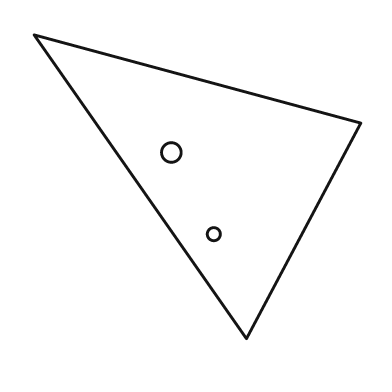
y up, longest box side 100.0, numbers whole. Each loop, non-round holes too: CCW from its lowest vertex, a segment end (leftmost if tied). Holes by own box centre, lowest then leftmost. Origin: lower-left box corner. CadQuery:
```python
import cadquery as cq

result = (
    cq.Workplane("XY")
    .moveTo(65.0, 0.0)
    .lineTo(100.0, 66.0)
    .lineTo(0.0, 93.0)
    .close()
    .moveTo(55.0, 32.0)
    .circle(2.0)
    .moveTo(42.0, 57.0)
    .circle(3.0)
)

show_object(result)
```